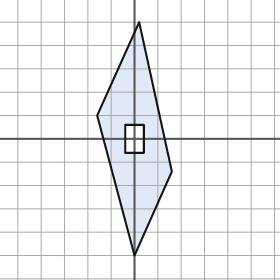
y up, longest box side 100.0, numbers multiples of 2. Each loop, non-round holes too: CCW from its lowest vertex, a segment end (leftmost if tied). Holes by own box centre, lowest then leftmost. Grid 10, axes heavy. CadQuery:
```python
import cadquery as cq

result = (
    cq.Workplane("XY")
    .moveTo(0.0, -50.0)
    .lineTo(16.0, -14.0)
    .lineTo(2.0, 50.0)
    .lineTo(-16.0, 10.0)
    .close()
    .moveTo(-4.0, -6.0)
    .lineTo(4.0, -6.0)
    .lineTo(4.0, 6.0)
    .lineTo(-4.0, 6.0)
    .close()
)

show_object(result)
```